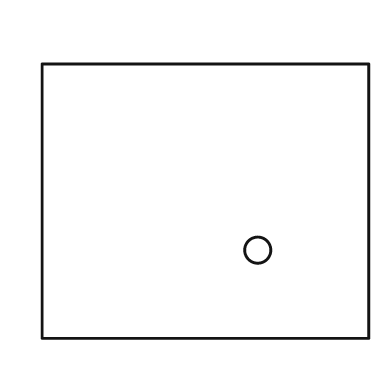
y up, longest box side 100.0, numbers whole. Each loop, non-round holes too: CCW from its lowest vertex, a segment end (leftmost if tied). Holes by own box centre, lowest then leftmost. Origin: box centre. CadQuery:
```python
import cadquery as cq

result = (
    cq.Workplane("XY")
    .moveTo(-50.0, -42.0)
    .lineTo(50.0, -42.0)
    .lineTo(50.0, 42.0)
    .lineTo(-50.0, 42.0)
    .close()
    .moveTo(16.0, -15.0)
    .circle(4.0)
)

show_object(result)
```